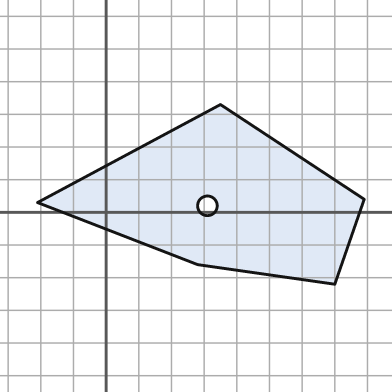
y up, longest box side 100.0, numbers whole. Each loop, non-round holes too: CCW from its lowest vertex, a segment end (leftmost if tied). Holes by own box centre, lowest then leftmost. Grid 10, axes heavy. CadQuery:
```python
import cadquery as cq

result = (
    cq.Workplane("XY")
    .moveTo(70.0, -22.0)
    .lineTo(79.0, 4.0)
    .lineTo(35.0, 33.0)
    .lineTo(-21.0, 3.0)
    .lineTo(28.0, -16.0)
    .close()
    .moveTo(31.0, 2.0)
    .circle(3.0)
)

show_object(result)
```